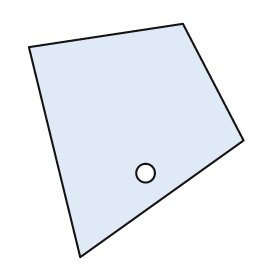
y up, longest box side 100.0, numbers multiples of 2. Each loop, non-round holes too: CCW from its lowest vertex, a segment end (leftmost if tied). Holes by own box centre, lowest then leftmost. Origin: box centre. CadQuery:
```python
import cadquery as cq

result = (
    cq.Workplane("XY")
    .moveTo(-24.0, -50.0)
    .lineTo(46.0, 0.0)
    .lineTo(20.0, 50.0)
    .lineTo(-46.0, 40.0)
    .close()
    .moveTo(4.0, -14.0)
    .circle(4.0)
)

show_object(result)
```